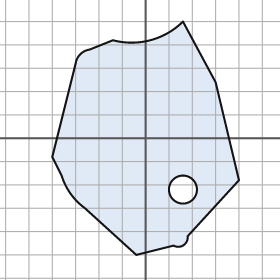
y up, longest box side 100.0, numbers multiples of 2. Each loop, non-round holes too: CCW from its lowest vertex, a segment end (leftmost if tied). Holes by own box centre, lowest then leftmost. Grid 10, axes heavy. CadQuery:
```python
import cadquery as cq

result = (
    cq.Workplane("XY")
    .moveTo(-4.0, -50.0)
    .lineTo(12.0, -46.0)
    .threePointArc((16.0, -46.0), (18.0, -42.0))
    .lineTo(40.0, -18.0)
    .lineTo(30.0, 24.0)
    .lineTo(16.0, 50.0)
    .threePointArc((2.0, 42.0), (-14.0, 42.0))
    .lineTo(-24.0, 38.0)
    .threePointArc((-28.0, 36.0), (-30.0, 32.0))
    .lineTo(-40.0, -8.0)
    .lineTo(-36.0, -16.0)
    .threePointArc((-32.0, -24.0), (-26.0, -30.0))
    .close()
    .moveTo(16.0, -22.0)
    .circle(6.0)
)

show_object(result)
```